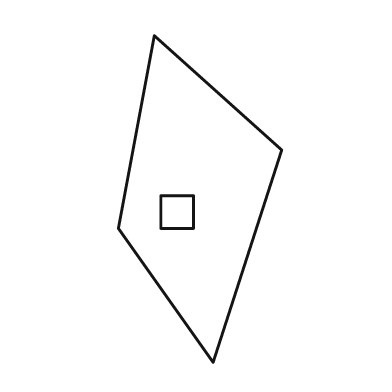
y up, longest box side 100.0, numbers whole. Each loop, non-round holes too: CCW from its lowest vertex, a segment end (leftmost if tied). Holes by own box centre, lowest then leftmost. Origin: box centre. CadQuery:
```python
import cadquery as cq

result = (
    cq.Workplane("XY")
    .moveTo(4.0, -50.0)
    .lineTo(25.0, 15.0)
    .lineTo(-14.0, 50.0)
    .lineTo(-25.0, -9.0)
    .close()
    .moveTo(-12.0, -9.0)
    .lineTo(-2.0, -9.0)
    .lineTo(-2.0, 1.0)
    .lineTo(-12.0, 1.0)
    .close()
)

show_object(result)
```